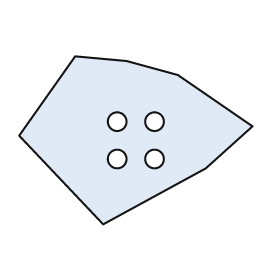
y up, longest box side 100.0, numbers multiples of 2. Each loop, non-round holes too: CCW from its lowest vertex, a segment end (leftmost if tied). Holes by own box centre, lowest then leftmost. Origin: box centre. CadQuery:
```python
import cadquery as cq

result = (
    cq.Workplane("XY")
    .moveTo(-14.0, -36.0)
    .lineTo(30.0, -12.0)
    .lineTo(50.0, 6.0)
    .lineTo(18.0, 28.0)
    .lineTo(-4.0, 34.0)
    .lineTo(-26.0, 36.0)
    .lineTo(-50.0, 2.0)
    .close()
    .moveTo(-8.0, -8.0)
    .circle(4.0)
    .moveTo(8.0, -8.0)
    .circle(4.0)
    .moveTo(-8.0, 8.0)
    .circle(4.0)
    .moveTo(8.0, 8.0)
    .circle(4.0)
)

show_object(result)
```